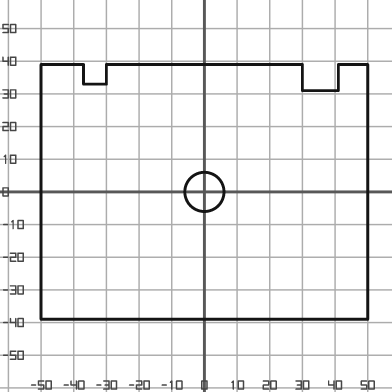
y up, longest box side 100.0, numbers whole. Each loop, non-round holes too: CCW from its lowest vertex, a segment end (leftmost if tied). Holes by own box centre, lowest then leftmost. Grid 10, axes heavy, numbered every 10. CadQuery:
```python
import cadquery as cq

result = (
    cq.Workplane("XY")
    .moveTo(-50.0, -39.0)
    .lineTo(50.0, -39.0)
    .lineTo(50.0, 39.0)
    .lineTo(41.0, 39.0)
    .lineTo(41.0, 31.0)
    .lineTo(30.0, 31.0)
    .lineTo(30.0, 39.0)
    .lineTo(-30.0, 39.0)
    .lineTo(-30.0, 33.0)
    .lineTo(-37.0, 33.0)
    .lineTo(-37.0, 39.0)
    .lineTo(-50.0, 39.0)
    .close()
    .moveTo(0.0, 0.0)
    .circle(6.0)
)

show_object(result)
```